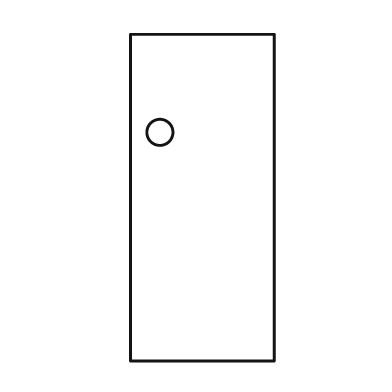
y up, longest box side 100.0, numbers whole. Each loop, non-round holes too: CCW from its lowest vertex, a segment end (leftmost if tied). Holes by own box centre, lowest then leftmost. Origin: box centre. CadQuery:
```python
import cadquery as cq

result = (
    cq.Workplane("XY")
    .moveTo(-22.0, -50.0)
    .lineTo(22.0, -50.0)
    .lineTo(22.0, 50.0)
    .lineTo(-22.0, 50.0)
    .close()
    .moveTo(-13.0, 20.0)
    .circle(4.0)
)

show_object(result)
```